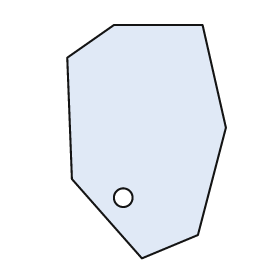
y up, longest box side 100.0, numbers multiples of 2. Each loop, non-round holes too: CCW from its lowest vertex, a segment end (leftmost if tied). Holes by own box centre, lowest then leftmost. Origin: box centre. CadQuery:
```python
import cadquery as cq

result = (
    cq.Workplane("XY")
    .moveTo(-2.0, -50.0)
    .lineTo(22.0, -40.0)
    .lineTo(34.0, 6.0)
    .lineTo(24.0, 50.0)
    .lineTo(-14.0, 50.0)
    .lineTo(-34.0, 36.0)
    .lineTo(-32.0, -16.0)
    .close()
    .moveTo(-10.0, -24.0)
    .circle(4.0)
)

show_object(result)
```